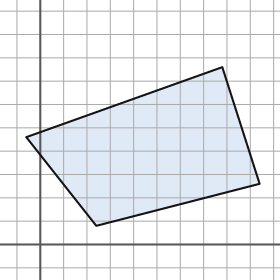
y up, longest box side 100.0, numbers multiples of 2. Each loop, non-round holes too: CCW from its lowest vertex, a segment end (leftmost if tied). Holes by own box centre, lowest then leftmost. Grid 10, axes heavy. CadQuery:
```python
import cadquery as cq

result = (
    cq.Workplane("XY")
    .moveTo(24.0, 8.0)
    .lineTo(94.0, 26.0)
    .lineTo(78.0, 76.0)
    .lineTo(-6.0, 46.0)
    .close()
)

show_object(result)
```